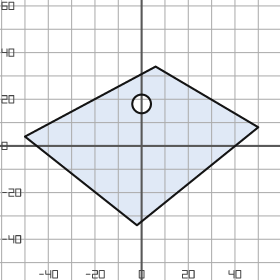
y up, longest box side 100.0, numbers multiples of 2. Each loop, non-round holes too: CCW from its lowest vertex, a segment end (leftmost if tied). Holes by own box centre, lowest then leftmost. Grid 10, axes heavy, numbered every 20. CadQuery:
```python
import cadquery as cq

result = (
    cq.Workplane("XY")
    .moveTo(-2.0, -34.0)
    .lineTo(50.0, 8.0)
    .lineTo(6.0, 34.0)
    .lineTo(-50.0, 4.0)
    .close()
    .moveTo(0.0, 18.0)
    .circle(4.0)
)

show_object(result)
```